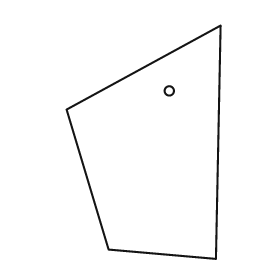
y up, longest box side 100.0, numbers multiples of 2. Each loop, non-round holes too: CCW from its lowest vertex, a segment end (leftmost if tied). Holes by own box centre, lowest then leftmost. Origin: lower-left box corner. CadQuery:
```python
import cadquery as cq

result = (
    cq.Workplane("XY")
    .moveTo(64.0, 0.0)
    .lineTo(66.0, 100.0)
    .lineTo(0.0, 64.0)
    .lineTo(18.0, 4.0)
    .close()
    .moveTo(44.0, 72.0)
    .circle(2.0)
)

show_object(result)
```